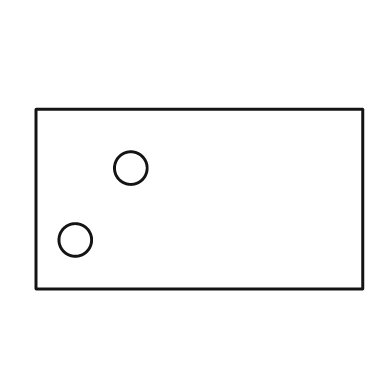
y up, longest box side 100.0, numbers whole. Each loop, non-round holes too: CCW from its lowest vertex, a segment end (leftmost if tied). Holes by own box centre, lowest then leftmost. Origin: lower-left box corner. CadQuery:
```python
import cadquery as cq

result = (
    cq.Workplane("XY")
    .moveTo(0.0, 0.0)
    .lineTo(100.0, 0.0)
    .lineTo(100.0, 55.0)
    .lineTo(0.0, 55.0)
    .close()
    .moveTo(12.0, 15.0)
    .circle(5.0)
    .moveTo(29.0, 37.0)
    .circle(5.0)
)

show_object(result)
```